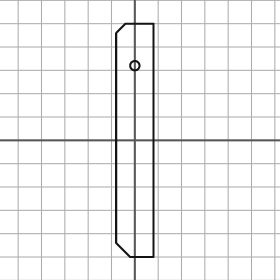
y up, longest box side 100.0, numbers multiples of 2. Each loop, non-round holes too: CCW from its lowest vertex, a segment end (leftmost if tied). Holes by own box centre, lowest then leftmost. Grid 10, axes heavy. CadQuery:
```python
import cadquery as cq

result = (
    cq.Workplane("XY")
    .moveTo(-2.0, -50.0)
    .lineTo(8.0, -50.0)
    .lineTo(8.0, 50.0)
    .lineTo(-4.0, 50.0)
    .lineTo(-8.0, 46.0)
    .lineTo(-8.0, -44.0)
    .close()
    .moveTo(0.0, 32.0)
    .circle(2.0)
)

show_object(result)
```